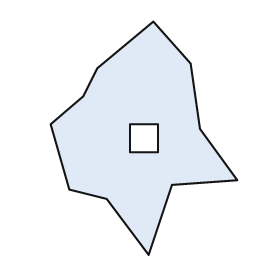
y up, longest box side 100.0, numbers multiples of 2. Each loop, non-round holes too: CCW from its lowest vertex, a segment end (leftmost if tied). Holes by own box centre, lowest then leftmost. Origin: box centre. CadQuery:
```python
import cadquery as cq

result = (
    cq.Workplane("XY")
    .moveTo(2.0, -50.0)
    .lineTo(12.0, -20.0)
    .lineTo(40.0, -18.0)
    .lineTo(24.0, 4.0)
    .lineTo(20.0, 32.0)
    .lineTo(4.0, 50.0)
    .lineTo(-20.0, 30.0)
    .lineTo(-26.0, 18.0)
    .lineTo(-40.0, 6.0)
    .lineTo(-32.0, -22.0)
    .lineTo(-16.0, -26.0)
    .close()
    .moveTo(-6.0, -6.0)
    .lineTo(6.0, -6.0)
    .lineTo(6.0, 6.0)
    .lineTo(-6.0, 6.0)
    .close()
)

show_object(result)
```